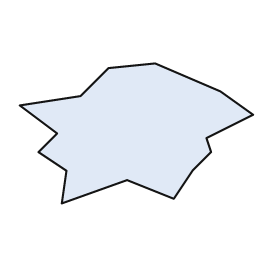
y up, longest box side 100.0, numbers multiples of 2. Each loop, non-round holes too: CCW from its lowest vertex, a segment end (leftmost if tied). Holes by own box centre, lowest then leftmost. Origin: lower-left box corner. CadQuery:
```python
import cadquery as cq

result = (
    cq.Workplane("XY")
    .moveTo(18.0, 0.0)
    .lineTo(46.0, 10.0)
    .lineTo(66.0, 2.0)
    .lineTo(74.0, 14.0)
    .lineTo(82.0, 22.0)
    .lineTo(80.0, 28.0)
    .lineTo(100.0, 38.0)
    .lineTo(86.0, 48.0)
    .lineTo(58.0, 60.0)
    .lineTo(38.0, 58.0)
    .lineTo(26.0, 46.0)
    .lineTo(0.0, 42.0)
    .lineTo(16.0, 30.0)
    .lineTo(8.0, 22.0)
    .lineTo(20.0, 14.0)
    .close()
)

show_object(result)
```